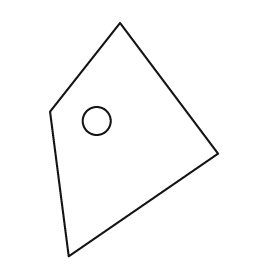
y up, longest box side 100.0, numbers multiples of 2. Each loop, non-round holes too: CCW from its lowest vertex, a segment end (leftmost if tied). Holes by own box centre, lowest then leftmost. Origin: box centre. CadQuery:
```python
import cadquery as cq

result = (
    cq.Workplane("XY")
    .moveTo(-28.0, -50.0)
    .lineTo(36.0, -6.0)
    .lineTo(-6.0, 50.0)
    .lineTo(-36.0, 12.0)
    .close()
    .moveTo(-16.0, 8.0)
    .circle(6.0)
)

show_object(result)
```